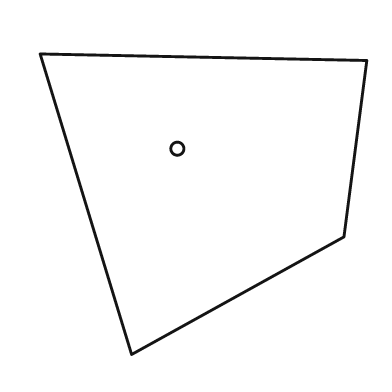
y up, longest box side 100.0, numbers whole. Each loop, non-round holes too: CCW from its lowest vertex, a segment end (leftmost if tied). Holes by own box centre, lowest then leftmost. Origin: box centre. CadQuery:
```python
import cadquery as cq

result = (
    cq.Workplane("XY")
    .moveTo(-22.0, -46.0)
    .lineTo(43.0, -10.0)
    .lineTo(50.0, 44.0)
    .lineTo(-50.0, 46.0)
    .close()
    .moveTo(-8.0, 17.0)
    .circle(2.0)
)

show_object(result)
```